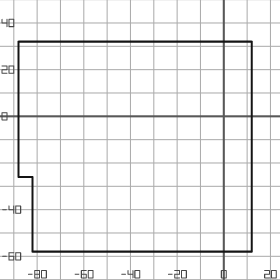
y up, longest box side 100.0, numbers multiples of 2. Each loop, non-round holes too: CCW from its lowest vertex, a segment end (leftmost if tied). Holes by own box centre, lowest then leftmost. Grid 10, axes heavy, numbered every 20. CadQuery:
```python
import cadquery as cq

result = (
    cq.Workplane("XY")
    .moveTo(-82.0, -58.0)
    .lineTo(12.0, -58.0)
    .lineTo(12.0, 32.0)
    .lineTo(-88.0, 32.0)
    .lineTo(-88.0, -26.0)
    .lineTo(-82.0, -26.0)
    .close()
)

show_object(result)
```